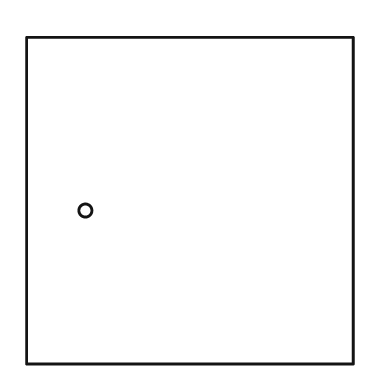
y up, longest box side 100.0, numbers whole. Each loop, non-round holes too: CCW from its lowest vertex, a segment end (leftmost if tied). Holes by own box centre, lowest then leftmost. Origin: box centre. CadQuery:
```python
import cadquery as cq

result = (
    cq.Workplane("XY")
    .moveTo(-50.0, -50.0)
    .lineTo(50.0, -50.0)
    .lineTo(50.0, 50.0)
    .lineTo(-50.0, 50.0)
    .close()
    .moveTo(-32.0, -3.0)
    .circle(2.0)
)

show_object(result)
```